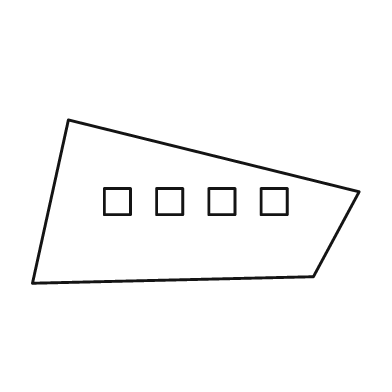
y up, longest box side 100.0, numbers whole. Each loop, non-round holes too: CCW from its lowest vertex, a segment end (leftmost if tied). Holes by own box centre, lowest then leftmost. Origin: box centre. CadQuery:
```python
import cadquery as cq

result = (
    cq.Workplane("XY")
    .moveTo(-50.0, -25.0)
    .lineTo(36.0, -23.0)
    .lineTo(50.0, 3.0)
    .lineTo(-39.0, 25.0)
    .close()
    .moveTo(-28.0, -4.0)
    .lineTo(-20.0, -4.0)
    .lineTo(-20.0, 4.0)
    .lineTo(-28.0, 4.0)
    .close()
    .moveTo(-12.0, -4.0)
    .lineTo(-4.0, -4.0)
    .lineTo(-4.0, 4.0)
    .lineTo(-12.0, 4.0)
    .close()
    .moveTo(4.0, -4.0)
    .lineTo(12.0, -4.0)
    .lineTo(12.0, 4.0)
    .lineTo(4.0, 4.0)
    .close()
    .moveTo(20.0, -4.0)
    .lineTo(28.0, -4.0)
    .lineTo(28.0, 4.0)
    .lineTo(20.0, 4.0)
    .close()
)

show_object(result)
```